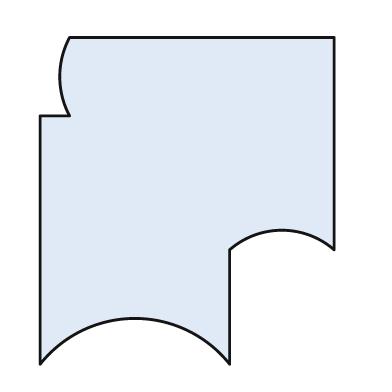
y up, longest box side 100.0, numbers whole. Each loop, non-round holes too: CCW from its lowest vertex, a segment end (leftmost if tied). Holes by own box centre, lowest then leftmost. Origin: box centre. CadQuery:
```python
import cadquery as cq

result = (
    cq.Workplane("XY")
    .moveTo(-45.0, -50.0)
    .threePointArc((-16.0, -36.0), (13.0, -50.0))
    .lineTo(13.0, -15.0)
    .threePointArc((29.0, -9.0), (45.0, -15.0))
    .lineTo(45.0, 50.0)
    .lineTo(-36.0, 50.0)
    .threePointArc((-39.0, 38.0), (-36.0, 26.0))
    .lineTo(-45.0, 26.0)
    .close()
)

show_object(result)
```